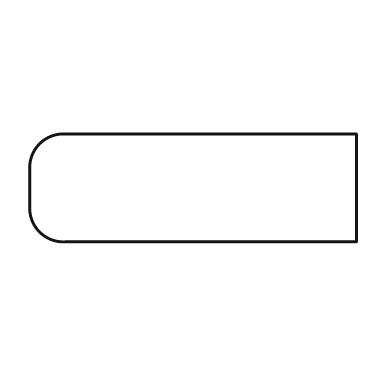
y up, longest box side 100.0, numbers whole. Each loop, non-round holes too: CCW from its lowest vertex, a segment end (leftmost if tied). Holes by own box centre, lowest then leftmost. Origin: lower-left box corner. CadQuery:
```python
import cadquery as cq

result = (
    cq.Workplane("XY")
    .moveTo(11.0, 0.0)
    .lineTo(100.0, 0.0)
    .lineTo(100.0, 33.0)
    .lineTo(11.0, 33.0)
    .threePointArc((3.0, 30.0), (0.0, 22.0))
    .lineTo(0.0, 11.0)
    .threePointArc((3.0, 3.0), (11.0, 0.0))
    .close()
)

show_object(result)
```